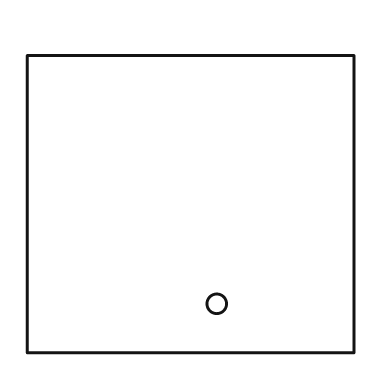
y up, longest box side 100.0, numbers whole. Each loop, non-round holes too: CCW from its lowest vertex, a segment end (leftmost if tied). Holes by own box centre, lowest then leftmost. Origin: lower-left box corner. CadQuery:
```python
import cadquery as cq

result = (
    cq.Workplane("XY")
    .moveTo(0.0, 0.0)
    .lineTo(100.0, 0.0)
    .lineTo(100.0, 91.0)
    .lineTo(0.0, 91.0)
    .close()
    .moveTo(58.0, 15.0)
    .circle(3.0)
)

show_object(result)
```